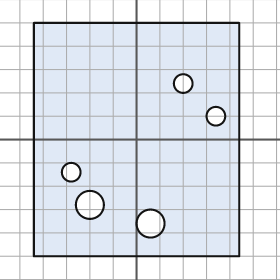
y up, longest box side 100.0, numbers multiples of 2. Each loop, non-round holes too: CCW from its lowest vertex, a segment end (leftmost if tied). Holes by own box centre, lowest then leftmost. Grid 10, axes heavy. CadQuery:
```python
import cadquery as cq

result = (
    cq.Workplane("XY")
    .moveTo(-44.0, -50.0)
    .lineTo(44.0, -50.0)
    .lineTo(44.0, 50.0)
    .lineTo(-44.0, 50.0)
    .close()
    .moveTo(6.0, -36.0)
    .circle(6.0)
    .moveTo(-20.0, -28.0)
    .circle(6.0)
    .moveTo(-28.0, -14.0)
    .circle(4.0)
    .moveTo(34.0, 10.0)
    .circle(4.0)
    .moveTo(20.0, 24.0)
    .circle(4.0)
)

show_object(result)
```